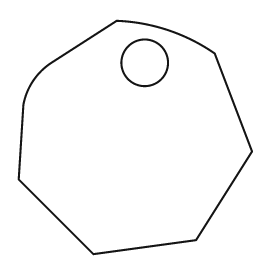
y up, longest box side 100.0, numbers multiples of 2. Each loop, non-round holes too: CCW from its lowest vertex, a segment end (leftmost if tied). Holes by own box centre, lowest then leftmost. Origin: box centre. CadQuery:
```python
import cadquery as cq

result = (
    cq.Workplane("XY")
    .moveTo(-18.0, -50.0)
    .lineTo(26.0, -44.0)
    .lineTo(50.0, -6.0)
    .lineTo(34.0, 36.0)
    .threePointArc((14.0, 46.0), (-8.0, 50.0))
    .lineTo(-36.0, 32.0)
    .threePointArc((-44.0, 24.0), (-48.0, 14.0))
    .lineTo(-50.0, -18.0)
    .close()
    .moveTo(4.0, 32.0)
    .circle(10.0)
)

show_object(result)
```